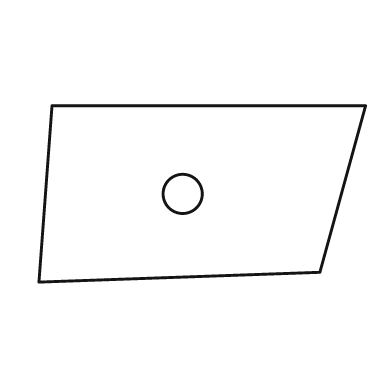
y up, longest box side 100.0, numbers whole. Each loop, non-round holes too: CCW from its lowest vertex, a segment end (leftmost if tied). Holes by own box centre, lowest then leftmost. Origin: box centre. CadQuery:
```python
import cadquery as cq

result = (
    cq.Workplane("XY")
    .moveTo(-50.0, -27.0)
    .lineTo(36.0, -24.0)
    .lineTo(50.0, 27.0)
    .lineTo(-46.0, 27.0)
    .close()
    .moveTo(-6.0, 0.0)
    .circle(6.0)
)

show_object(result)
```